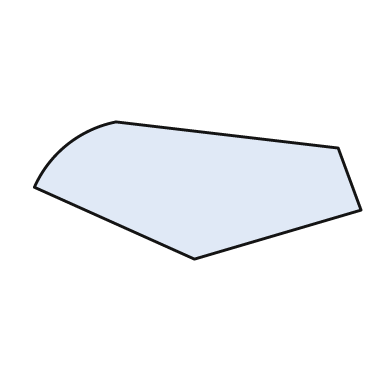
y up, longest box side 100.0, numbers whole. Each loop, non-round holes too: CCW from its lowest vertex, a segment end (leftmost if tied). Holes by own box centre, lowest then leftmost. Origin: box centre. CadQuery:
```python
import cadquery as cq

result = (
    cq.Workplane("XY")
    .moveTo(-1.0, -21.0)
    .lineTo(50.0, -6.0)
    .lineTo(43.0, 13.0)
    .lineTo(-25.0, 21.0)
    .threePointArc((-40.0, 14.0), (-50.0, 1.0))
    .close()
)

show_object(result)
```